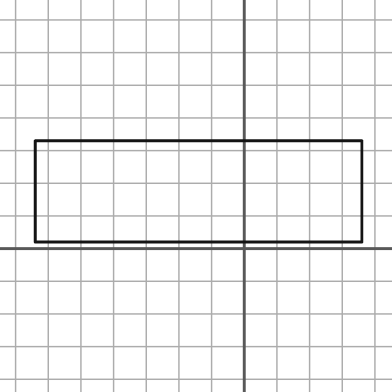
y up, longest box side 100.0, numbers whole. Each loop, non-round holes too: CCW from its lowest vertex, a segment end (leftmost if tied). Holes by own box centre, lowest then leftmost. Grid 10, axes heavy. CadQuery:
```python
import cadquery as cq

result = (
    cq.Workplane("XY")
    .moveTo(-64.0, 2.0)
    .lineTo(36.0, 2.0)
    .lineTo(36.0, 33.0)
    .lineTo(-64.0, 33.0)
    .close()
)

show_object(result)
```